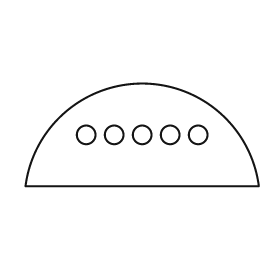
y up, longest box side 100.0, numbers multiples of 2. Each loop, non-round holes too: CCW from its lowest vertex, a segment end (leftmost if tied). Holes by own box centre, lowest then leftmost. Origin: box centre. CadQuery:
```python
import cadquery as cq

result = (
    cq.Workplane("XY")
    .moveTo(-50.0, -22.0)
    .lineTo(50.0, -22.0)
    .threePointArc((0.0, 22.0), (-50.0, -22.0))
    .close()
    .moveTo(-24.0, 0.0)
    .circle(4.0)
    .moveTo(-12.0, 0.0)
    .circle(4.0)
    .moveTo(0.0, 0.0)
    .circle(4.0)
    .moveTo(12.0, 0.0)
    .circle(4.0)
    .moveTo(24.0, 0.0)
    .circle(4.0)
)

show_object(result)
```